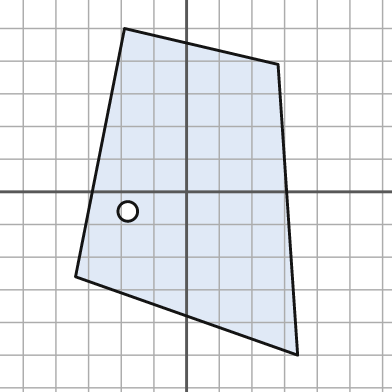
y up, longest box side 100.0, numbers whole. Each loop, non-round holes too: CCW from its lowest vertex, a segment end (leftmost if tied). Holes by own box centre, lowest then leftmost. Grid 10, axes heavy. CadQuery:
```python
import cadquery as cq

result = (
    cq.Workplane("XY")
    .moveTo(34.0, -50.0)
    .lineTo(28.0, 39.0)
    .lineTo(-19.0, 50.0)
    .lineTo(-34.0, -26.0)
    .close()
    .moveTo(-18.0, -6.0)
    .circle(3.0)
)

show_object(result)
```